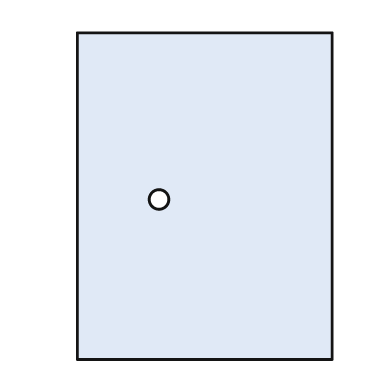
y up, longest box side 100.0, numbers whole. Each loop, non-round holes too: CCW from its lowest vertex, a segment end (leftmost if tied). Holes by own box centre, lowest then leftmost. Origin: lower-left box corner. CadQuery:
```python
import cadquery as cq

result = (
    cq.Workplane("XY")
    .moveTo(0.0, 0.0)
    .lineTo(78.0, 0.0)
    .lineTo(78.0, 100.0)
    .lineTo(0.0, 100.0)
    .close()
    .moveTo(25.0, 49.0)
    .circle(3.0)
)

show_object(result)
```